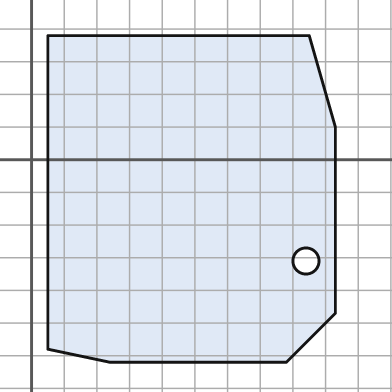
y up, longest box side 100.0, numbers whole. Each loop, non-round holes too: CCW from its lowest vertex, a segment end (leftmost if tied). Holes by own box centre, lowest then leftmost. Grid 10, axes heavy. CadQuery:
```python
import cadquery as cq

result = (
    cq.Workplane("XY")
    .moveTo(24.0, -62.0)
    .lineTo(78.0, -62.0)
    .lineTo(93.0, -47.0)
    .lineTo(93.0, 10.0)
    .lineTo(85.0, 38.0)
    .lineTo(5.0, 38.0)
    .lineTo(5.0, -58.0)
    .close()
    .moveTo(84.0, -31.0)
    .circle(4.0)
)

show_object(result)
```